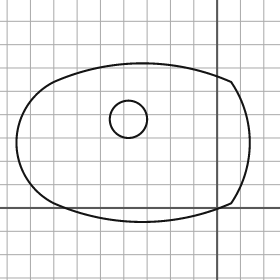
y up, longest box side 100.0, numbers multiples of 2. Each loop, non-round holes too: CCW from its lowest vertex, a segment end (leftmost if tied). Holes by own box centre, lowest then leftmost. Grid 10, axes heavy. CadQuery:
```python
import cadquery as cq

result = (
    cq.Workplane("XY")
    .moveTo(-70.0, 2.0)
    .threePointArc((-32.0, -6.0), (6.0, 2.0))
    .threePointArc((14.0, 28.0), (6.0, 54.0))
    .threePointArc((-32.0, 62.0), (-70.0, 54.0))
    .threePointArc((-86.0, 28.0), (-70.0, 2.0))
    .close()
    .moveTo(-38.0, 38.0)
    .circle(8.0)
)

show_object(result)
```